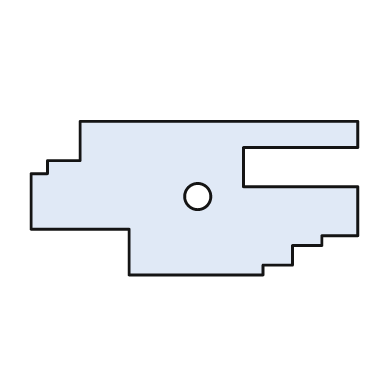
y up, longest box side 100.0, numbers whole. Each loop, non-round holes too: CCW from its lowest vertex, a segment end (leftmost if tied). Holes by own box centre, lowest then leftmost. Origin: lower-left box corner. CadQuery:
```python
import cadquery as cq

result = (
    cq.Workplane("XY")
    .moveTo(30.0, 0.0)
    .lineTo(71.0, 0.0)
    .lineTo(71.0, 3.0)
    .lineTo(80.0, 3.0)
    .lineTo(80.0, 9.0)
    .lineTo(89.0, 9.0)
    .lineTo(89.0, 12.0)
    .lineTo(100.0, 12.0)
    .lineTo(100.0, 27.0)
    .lineTo(65.0, 27.0)
    .lineTo(65.0, 39.0)
    .lineTo(100.0, 39.0)
    .lineTo(100.0, 47.0)
    .lineTo(15.0, 47.0)
    .lineTo(15.0, 35.0)
    .lineTo(5.0, 35.0)
    .lineTo(5.0, 31.0)
    .lineTo(0.0, 31.0)
    .lineTo(0.0, 14.0)
    .lineTo(30.0, 14.0)
    .close()
    .moveTo(51.0, 24.0)
    .circle(4.0)
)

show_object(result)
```